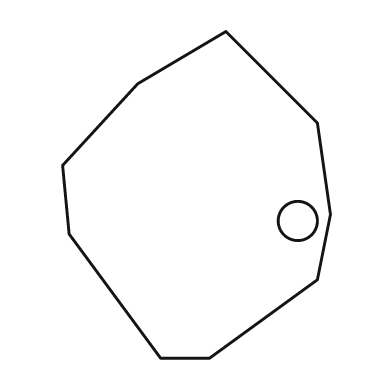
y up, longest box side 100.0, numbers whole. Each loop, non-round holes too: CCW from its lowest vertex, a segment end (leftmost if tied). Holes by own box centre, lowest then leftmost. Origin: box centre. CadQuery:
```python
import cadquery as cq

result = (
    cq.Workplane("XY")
    .moveTo(-11.0, -50.0)
    .lineTo(4.0, -50.0)
    .lineTo(37.0, -26.0)
    .lineTo(41.0, -6.0)
    .lineTo(37.0, 22.0)
    .lineTo(9.0, 50.0)
    .lineTo(-18.0, 34.0)
    .lineTo(-41.0, 9.0)
    .lineTo(-39.0, -12.0)
    .close()
    .moveTo(31.0, -8.0)
    .circle(6.0)
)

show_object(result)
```